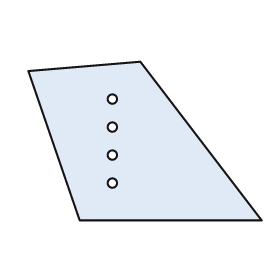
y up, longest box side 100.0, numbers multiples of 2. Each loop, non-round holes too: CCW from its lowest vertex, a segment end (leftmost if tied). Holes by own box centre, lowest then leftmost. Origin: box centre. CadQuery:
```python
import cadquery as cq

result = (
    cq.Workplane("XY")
    .moveTo(-28.0, -34.0)
    .lineTo(50.0, -34.0)
    .lineTo(-2.0, 34.0)
    .lineTo(-50.0, 30.0)
    .close()
    .moveTo(-14.0, -18.0)
    .circle(2.0)
    .moveTo(-14.0, -6.0)
    .circle(2.0)
    .moveTo(-14.0, 6.0)
    .circle(2.0)
    .moveTo(-14.0, 18.0)
    .circle(2.0)
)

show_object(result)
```